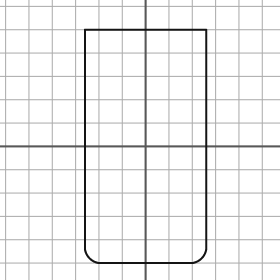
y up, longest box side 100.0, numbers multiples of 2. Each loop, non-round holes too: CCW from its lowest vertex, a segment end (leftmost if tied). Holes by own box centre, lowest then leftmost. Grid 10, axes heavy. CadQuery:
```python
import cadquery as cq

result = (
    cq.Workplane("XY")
    .moveTo(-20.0, -50.0)
    .lineTo(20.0, -50.0)
    .threePointArc((24.0, -48.0), (26.0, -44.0))
    .lineTo(26.0, 50.0)
    .lineTo(-26.0, 50.0)
    .lineTo(-26.0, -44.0)
    .threePointArc((-24.0, -48.0), (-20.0, -50.0))
    .close()
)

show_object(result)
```